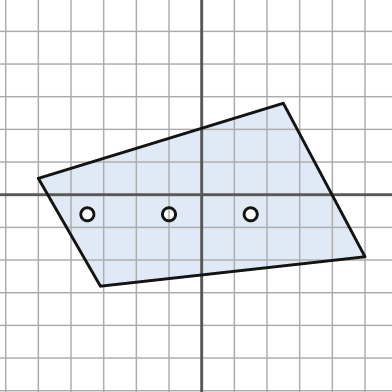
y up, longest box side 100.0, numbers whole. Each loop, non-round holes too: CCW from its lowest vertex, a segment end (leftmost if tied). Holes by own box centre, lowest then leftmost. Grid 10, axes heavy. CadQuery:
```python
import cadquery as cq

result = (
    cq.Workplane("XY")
    .moveTo(-31.0, -28.0)
    .lineTo(50.0, -19.0)
    .lineTo(25.0, 28.0)
    .lineTo(-50.0, 5.0)
    .close()
    .moveTo(-35.0, -6.0)
    .circle(2.0)
    .moveTo(-10.0, -6.0)
    .circle(2.0)
    .moveTo(15.0, -6.0)
    .circle(2.0)
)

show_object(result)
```